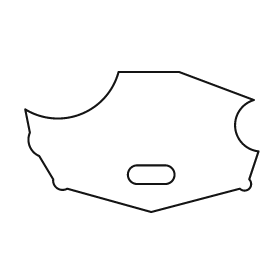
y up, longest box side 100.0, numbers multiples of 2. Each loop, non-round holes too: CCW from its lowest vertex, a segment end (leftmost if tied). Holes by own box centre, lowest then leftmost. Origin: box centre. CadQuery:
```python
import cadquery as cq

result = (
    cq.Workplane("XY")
    .moveTo(4.0, -30.0)
    .lineTo(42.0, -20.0)
    .threePointArc((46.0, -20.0), (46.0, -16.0))
    .lineTo(50.0, -4.0)
    .threePointArc((40.0, 6.0), (48.0, 18.0))
    .lineTo(16.0, 30.0)
    .lineTo(-10.0, 30.0)
    .threePointArc((-26.0, 12.0), (-50.0, 14.0))
    .lineTo(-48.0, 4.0)
    .threePointArc((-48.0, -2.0), (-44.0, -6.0))
    .lineTo(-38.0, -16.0)
    .threePointArc((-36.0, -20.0), (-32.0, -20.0))
    .close()
    .moveTo(-2.0, -18.0)
    .lineTo(10.0, -18.0)
    .threePointArc((14.0, -14.0), (10.0, -10.0))
    .lineTo(-2.0, -10.0)
    .threePointArc((-6.0, -14.0), (-2.0, -18.0))
    .close()
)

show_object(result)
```